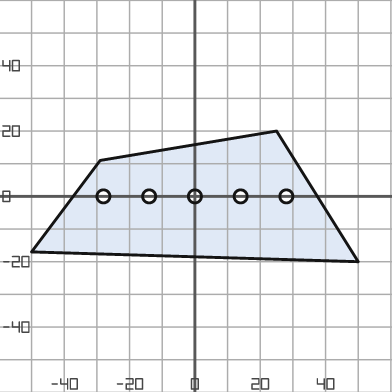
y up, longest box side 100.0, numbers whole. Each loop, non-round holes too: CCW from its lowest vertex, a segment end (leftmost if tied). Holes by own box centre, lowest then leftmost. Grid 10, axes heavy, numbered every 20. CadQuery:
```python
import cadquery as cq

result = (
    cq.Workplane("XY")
    .moveTo(50.0, -20.0)
    .lineTo(25.0, 20.0)
    .lineTo(-29.0, 11.0)
    .lineTo(-50.0, -17.0)
    .close()
    .moveTo(-28.0, 0.0)
    .circle(2.0)
    .moveTo(-14.0, 0.0)
    .circle(2.0)
    .moveTo(0.0, 0.0)
    .circle(2.0)
    .moveTo(14.0, 0.0)
    .circle(2.0)
    .moveTo(28.0, 0.0)
    .circle(2.0)
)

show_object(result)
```